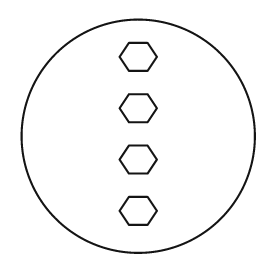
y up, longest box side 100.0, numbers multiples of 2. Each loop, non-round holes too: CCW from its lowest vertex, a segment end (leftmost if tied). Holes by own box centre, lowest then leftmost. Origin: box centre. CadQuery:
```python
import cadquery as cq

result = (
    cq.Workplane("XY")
    .moveTo(0.0, 0.0)
    .circle(50.0)
    .moveTo(-4.0, -38.0)
    .lineTo(4.0, -38.0)
    .lineTo(8.0, -32.0)
    .lineTo(4.0, -26.0)
    .lineTo(-4.0, -26.0)
    .lineTo(-8.0, -32.0)
    .close()
    .moveTo(-4.0, -16.0)
    .lineTo(4.0, -16.0)
    .lineTo(8.0, -10.0)
    .lineTo(4.0, -4.0)
    .lineTo(-4.0, -4.0)
    .lineTo(-8.0, -10.0)
    .close()
    .moveTo(-4.0, 6.0)
    .lineTo(4.0, 6.0)
    .lineTo(8.0, 12.0)
    .lineTo(4.0, 18.0)
    .lineTo(-4.0, 18.0)
    .lineTo(-8.0, 12.0)
    .close()
    .moveTo(-4.0, 28.0)
    .lineTo(4.0, 28.0)
    .lineTo(8.0, 34.0)
    .lineTo(4.0, 40.0)
    .lineTo(-4.0, 40.0)
    .lineTo(-8.0, 34.0)
    .close()
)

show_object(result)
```